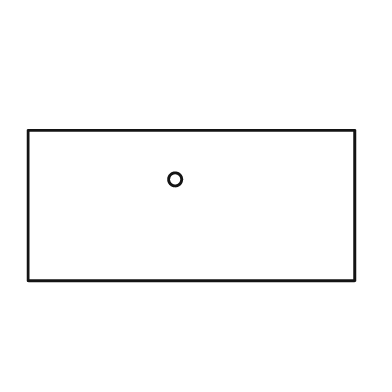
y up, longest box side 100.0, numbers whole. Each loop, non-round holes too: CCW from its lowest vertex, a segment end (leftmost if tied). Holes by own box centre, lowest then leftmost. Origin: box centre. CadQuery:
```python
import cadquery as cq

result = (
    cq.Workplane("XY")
    .moveTo(-50.0, -23.0)
    .lineTo(50.0, -23.0)
    .lineTo(50.0, 23.0)
    .lineTo(-50.0, 23.0)
    .close()
    .moveTo(-5.0, 8.0)
    .circle(2.0)
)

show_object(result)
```